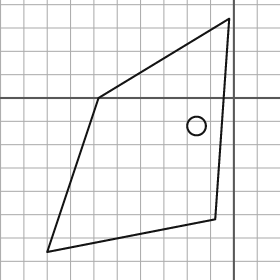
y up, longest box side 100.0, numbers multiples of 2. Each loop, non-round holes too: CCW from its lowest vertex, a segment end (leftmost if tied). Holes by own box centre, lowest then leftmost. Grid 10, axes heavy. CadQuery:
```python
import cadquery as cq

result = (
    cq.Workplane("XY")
    .moveTo(-80.0, -66.0)
    .lineTo(-8.0, -52.0)
    .lineTo(-2.0, 34.0)
    .lineTo(-58.0, 0.0)
    .close()
    .moveTo(-16.0, -12.0)
    .circle(4.0)
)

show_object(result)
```